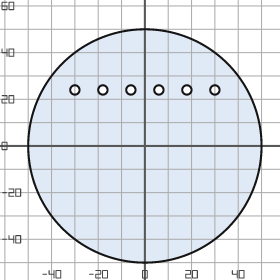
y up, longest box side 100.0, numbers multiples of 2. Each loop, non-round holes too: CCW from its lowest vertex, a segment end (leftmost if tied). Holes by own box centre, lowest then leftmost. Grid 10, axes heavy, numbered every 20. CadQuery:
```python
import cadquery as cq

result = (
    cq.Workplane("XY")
    .moveTo(0.0, 0.0)
    .circle(50.0)
    .moveTo(-30.0, 24.0)
    .circle(2.0)
    .moveTo(-18.0, 24.0)
    .circle(2.0)
    .moveTo(-6.0, 24.0)
    .circle(2.0)
    .moveTo(6.0, 24.0)
    .circle(2.0)
    .moveTo(18.0, 24.0)
    .circle(2.0)
    .moveTo(30.0, 24.0)
    .circle(2.0)
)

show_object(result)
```